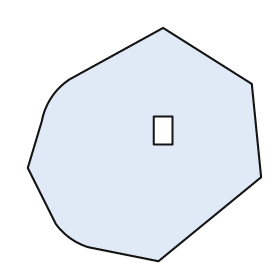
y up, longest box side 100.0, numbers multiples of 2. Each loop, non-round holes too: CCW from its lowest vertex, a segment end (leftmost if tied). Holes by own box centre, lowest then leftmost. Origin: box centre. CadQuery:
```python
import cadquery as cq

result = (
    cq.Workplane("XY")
    .moveTo(6.0, -50.0)
    .lineTo(50.0, -14.0)
    .lineTo(46.0, 26.0)
    .lineTo(8.0, 50.0)
    .lineTo(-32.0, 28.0)
    .threePointArc((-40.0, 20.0), (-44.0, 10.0))
    .lineTo(-50.0, -10.0)
    .lineTo(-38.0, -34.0)
    .threePointArc((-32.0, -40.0), (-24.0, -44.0))
    .close()
    .moveTo(4.0, 0.0)
    .lineTo(12.0, 0.0)
    .lineTo(12.0, 12.0)
    .lineTo(4.0, 12.0)
    .close()
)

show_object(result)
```